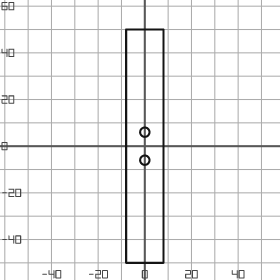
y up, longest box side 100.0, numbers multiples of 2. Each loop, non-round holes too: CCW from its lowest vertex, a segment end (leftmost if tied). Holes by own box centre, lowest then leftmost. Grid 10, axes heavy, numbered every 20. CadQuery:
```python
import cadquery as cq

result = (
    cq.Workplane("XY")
    .moveTo(-8.0, -50.0)
    .lineTo(8.0, -50.0)
    .lineTo(8.0, 50.0)
    .lineTo(-8.0, 50.0)
    .close()
    .moveTo(0.0, -6.0)
    .circle(2.0)
    .moveTo(0.0, 6.0)
    .circle(2.0)
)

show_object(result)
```